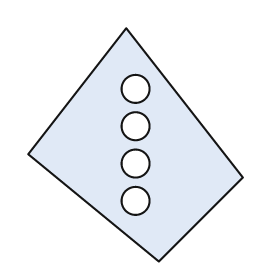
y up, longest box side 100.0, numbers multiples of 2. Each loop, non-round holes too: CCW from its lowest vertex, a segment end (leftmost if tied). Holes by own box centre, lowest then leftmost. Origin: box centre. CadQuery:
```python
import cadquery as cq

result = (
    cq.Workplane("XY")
    .moveTo(10.0, -50.0)
    .lineTo(46.0, -14.0)
    .lineTo(-4.0, 50.0)
    .lineTo(-46.0, -4.0)
    .close()
    .moveTo(0.0, -24.0)
    .circle(6.0)
    .moveTo(0.0, -8.0)
    .circle(6.0)
    .moveTo(0.0, 8.0)
    .circle(6.0)
    .moveTo(0.0, 24.0)
    .circle(6.0)
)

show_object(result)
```